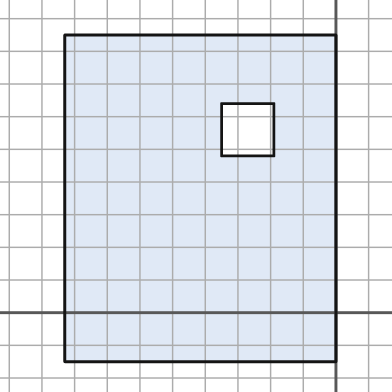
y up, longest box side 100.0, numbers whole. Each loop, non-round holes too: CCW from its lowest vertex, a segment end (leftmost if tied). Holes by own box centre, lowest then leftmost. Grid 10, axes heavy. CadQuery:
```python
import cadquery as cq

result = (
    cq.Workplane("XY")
    .moveTo(-83.0, -15.0)
    .lineTo(0.0, -15.0)
    .lineTo(0.0, 85.0)
    .lineTo(-83.0, 85.0)
    .close()
    .moveTo(-35.0, 48.0)
    .lineTo(-19.0, 48.0)
    .lineTo(-19.0, 64.0)
    .lineTo(-35.0, 64.0)
    .close()
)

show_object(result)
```